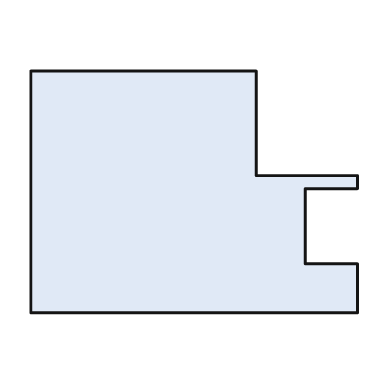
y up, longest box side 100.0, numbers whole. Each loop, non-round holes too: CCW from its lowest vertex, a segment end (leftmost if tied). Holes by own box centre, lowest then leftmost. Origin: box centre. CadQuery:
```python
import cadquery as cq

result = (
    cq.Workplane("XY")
    .moveTo(-50.0, -37.0)
    .lineTo(50.0, -37.0)
    .lineTo(50.0, -22.0)
    .lineTo(34.0, -22.0)
    .lineTo(34.0, 1.0)
    .lineTo(50.0, 1.0)
    .lineTo(50.0, 5.0)
    .lineTo(19.0, 5.0)
    .lineTo(19.0, 37.0)
    .lineTo(-50.0, 37.0)
    .close()
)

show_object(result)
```